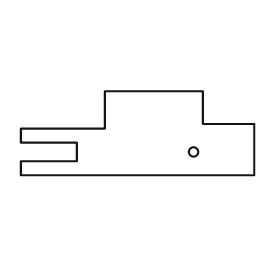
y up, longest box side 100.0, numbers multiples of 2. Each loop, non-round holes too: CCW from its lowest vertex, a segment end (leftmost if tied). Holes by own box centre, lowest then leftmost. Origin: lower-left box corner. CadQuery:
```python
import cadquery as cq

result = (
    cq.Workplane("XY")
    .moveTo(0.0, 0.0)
    .lineTo(100.0, 0.0)
    .lineTo(100.0, 22.0)
    .lineTo(78.0, 22.0)
    .lineTo(78.0, 36.0)
    .lineTo(36.0, 36.0)
    .lineTo(36.0, 20.0)
    .lineTo(0.0, 20.0)
    .lineTo(0.0, 14.0)
    .lineTo(24.0, 14.0)
    .lineTo(24.0, 6.0)
    .lineTo(0.0, 6.0)
    .close()
    .moveTo(74.0, 10.0)
    .circle(2.0)
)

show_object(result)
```